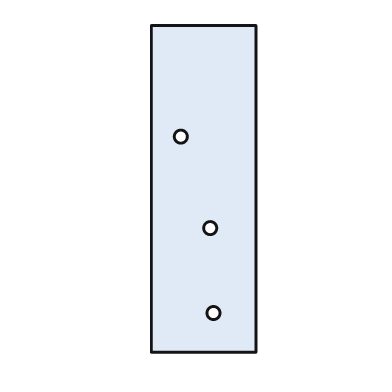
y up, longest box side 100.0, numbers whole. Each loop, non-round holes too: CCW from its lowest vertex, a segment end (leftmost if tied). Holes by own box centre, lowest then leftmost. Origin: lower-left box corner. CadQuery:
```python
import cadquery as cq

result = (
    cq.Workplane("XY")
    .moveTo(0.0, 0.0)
    .lineTo(32.0, 0.0)
    .lineTo(32.0, 100.0)
    .lineTo(0.0, 100.0)
    .close()
    .moveTo(19.0, 12.0)
    .circle(2.0)
    .moveTo(18.0, 38.0)
    .circle(2.0)
    .moveTo(9.0, 66.0)
    .circle(2.0)
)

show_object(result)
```